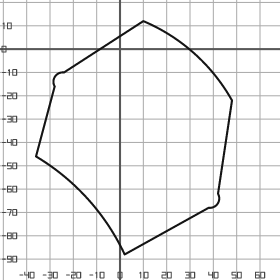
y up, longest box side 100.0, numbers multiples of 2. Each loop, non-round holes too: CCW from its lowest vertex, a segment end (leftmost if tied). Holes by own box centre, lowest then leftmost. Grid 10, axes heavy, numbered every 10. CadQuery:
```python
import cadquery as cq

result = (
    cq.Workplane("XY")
    .moveTo(2.0, -88.0)
    .lineTo(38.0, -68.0)
    .threePointArc((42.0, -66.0), (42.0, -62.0))
    .lineTo(48.0, -22.0)
    .threePointArc((32.0, -2.0), (10.0, 12.0))
    .lineTo(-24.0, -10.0)
    .threePointArc((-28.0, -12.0), (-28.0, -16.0))
    .lineTo(-36.0, -46.0)
    .threePointArc((-14.0, -64.0), (2.0, -88.0))
    .close()
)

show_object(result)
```